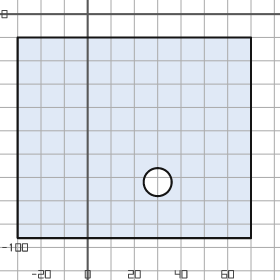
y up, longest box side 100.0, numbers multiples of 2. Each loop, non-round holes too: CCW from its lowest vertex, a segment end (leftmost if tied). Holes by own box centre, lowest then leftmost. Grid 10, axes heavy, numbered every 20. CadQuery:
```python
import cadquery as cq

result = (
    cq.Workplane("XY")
    .moveTo(-30.0, -96.0)
    .lineTo(70.0, -96.0)
    .lineTo(70.0, -10.0)
    .lineTo(-30.0, -10.0)
    .close()
    .moveTo(30.0, -72.0)
    .circle(6.0)
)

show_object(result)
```